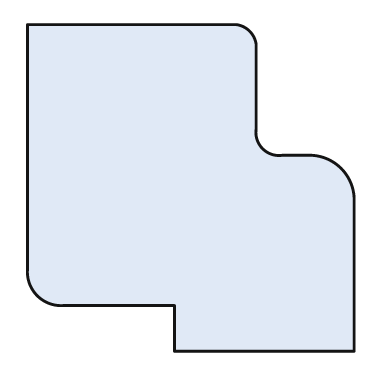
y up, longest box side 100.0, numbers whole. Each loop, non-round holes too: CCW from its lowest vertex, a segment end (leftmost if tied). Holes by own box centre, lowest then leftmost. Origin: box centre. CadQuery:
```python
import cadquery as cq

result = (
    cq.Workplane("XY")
    .moveTo(-5.0, -50.0)
    .lineTo(50.0, -50.0)
    .lineTo(50.0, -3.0)
    .threePointArc((46.0, 6.0), (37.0, 10.0))
    .lineTo(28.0, 10.0)
    .threePointArc((22.0, 12.0), (20.0, 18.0))
    .lineTo(20.0, 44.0)
    .threePointArc((18.0, 48.0), (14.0, 50.0))
    .lineTo(-50.0, 50.0)
    .lineTo(-50.0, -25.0)
    .threePointArc((-47.0, -33.0), (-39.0, -36.0))
    .lineTo(-5.0, -36.0)
    .close()
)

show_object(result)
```